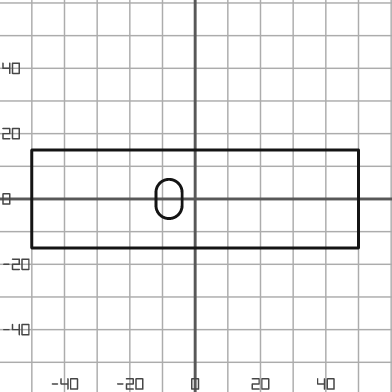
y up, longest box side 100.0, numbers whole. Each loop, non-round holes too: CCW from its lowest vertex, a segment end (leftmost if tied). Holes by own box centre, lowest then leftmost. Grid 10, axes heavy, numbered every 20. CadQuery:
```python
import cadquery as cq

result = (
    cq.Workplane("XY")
    .moveTo(-50.0, -15.0)
    .lineTo(50.0, -15.0)
    .lineTo(50.0, 15.0)
    .lineTo(-50.0, 15.0)
    .close()
    .moveTo(-12.0, -2.0)
    .threePointArc((-8.0, -6.0), (-4.0, -2.0))
    .lineTo(-4.0, 2.0)
    .threePointArc((-8.0, 6.0), (-12.0, 2.0))
    .close()
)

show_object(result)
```